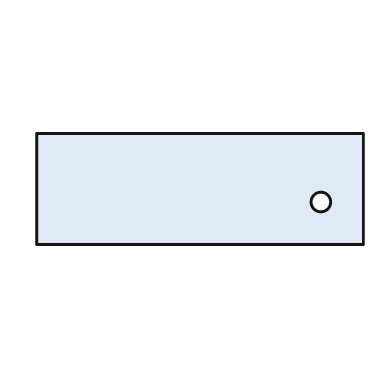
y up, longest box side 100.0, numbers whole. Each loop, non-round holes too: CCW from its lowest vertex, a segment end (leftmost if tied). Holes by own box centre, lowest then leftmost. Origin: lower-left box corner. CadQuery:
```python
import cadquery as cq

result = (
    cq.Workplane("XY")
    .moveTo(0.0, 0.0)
    .lineTo(100.0, 0.0)
    .lineTo(100.0, 34.0)
    .lineTo(0.0, 34.0)
    .close()
    .moveTo(87.0, 13.0)
    .circle(3.0)
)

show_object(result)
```